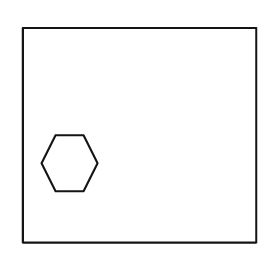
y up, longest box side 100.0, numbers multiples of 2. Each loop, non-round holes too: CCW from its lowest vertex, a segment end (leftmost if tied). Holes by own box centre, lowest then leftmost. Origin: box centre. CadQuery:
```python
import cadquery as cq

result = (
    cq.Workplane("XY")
    .moveTo(-50.0, -46.0)
    .lineTo(50.0, -46.0)
    .lineTo(50.0, 46.0)
    .lineTo(-50.0, 46.0)
    .close()
    .moveTo(-36.0, -24.0)
    .lineTo(-24.0, -24.0)
    .lineTo(-18.0, -12.0)
    .lineTo(-24.0, 0.0)
    .lineTo(-36.0, 0.0)
    .lineTo(-42.0, -12.0)
    .close()
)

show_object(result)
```